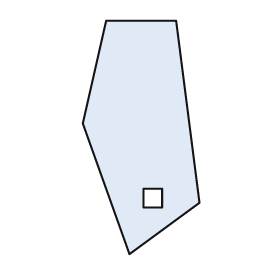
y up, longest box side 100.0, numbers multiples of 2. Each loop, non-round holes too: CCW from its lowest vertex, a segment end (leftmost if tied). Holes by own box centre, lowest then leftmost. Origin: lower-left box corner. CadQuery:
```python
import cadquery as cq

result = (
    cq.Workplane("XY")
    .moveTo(20.0, 0.0)
    .lineTo(50.0, 22.0)
    .lineTo(40.0, 100.0)
    .lineTo(10.0, 100.0)
    .lineTo(0.0, 56.0)
    .close()
    .moveTo(26.0, 20.0)
    .lineTo(34.0, 20.0)
    .lineTo(34.0, 28.0)
    .lineTo(26.0, 28.0)
    .close()
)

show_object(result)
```